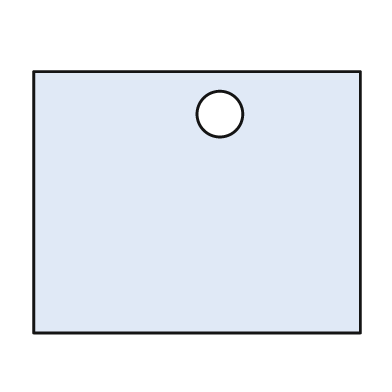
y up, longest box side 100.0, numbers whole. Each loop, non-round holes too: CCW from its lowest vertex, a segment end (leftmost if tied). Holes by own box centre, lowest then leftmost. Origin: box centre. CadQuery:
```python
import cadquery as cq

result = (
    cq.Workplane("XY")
    .moveTo(-50.0, -40.0)
    .lineTo(50.0, -40.0)
    .lineTo(50.0, 40.0)
    .lineTo(-50.0, 40.0)
    .close()
    .moveTo(7.0, 27.0)
    .circle(7.0)
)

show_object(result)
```